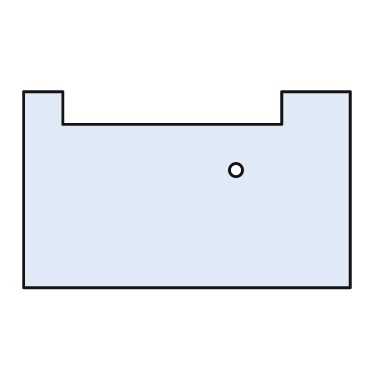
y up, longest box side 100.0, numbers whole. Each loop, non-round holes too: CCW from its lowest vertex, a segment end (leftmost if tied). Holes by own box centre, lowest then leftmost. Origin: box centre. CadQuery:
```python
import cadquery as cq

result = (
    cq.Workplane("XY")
    .moveTo(-50.0, -30.0)
    .lineTo(50.0, -30.0)
    .lineTo(50.0, 30.0)
    .lineTo(29.0, 30.0)
    .lineTo(29.0, 20.0)
    .lineTo(-38.0, 20.0)
    .lineTo(-38.0, 30.0)
    .lineTo(-50.0, 30.0)
    .close()
    .moveTo(15.0, 6.0)
    .circle(2.0)
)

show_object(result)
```